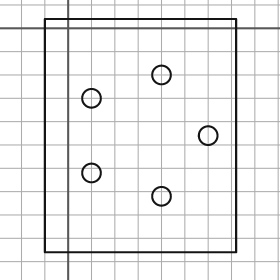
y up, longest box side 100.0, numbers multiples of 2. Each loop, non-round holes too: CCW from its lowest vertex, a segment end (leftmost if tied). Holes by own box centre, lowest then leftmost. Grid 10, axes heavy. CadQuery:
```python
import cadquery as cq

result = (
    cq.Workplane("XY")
    .moveTo(-10.0, -96.0)
    .lineTo(72.0, -96.0)
    .lineTo(72.0, 4.0)
    .lineTo(-10.0, 4.0)
    .close()
    .moveTo(40.0, -72.0)
    .circle(4.0)
    .moveTo(10.0, -62.0)
    .circle(4.0)
    .moveTo(60.0, -46.0)
    .circle(4.0)
    .moveTo(10.0, -30.0)
    .circle(4.0)
    .moveTo(40.0, -20.0)
    .circle(4.0)
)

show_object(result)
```